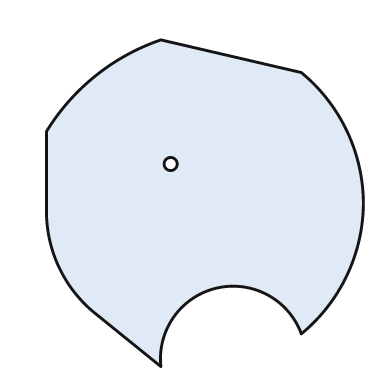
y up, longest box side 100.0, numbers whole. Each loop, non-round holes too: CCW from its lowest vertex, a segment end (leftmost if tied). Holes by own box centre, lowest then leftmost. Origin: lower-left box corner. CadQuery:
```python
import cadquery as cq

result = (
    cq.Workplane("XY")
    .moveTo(35.0, 0.0)
    .threePointArc((52.0, 24.0), (78.0, 10.0))
    .threePointArc((92.0, 28.0), (97.0, 50.0))
    .threePointArc((92.0, 72.0), (78.0, 90.0))
    .lineTo(35.0, 100.0)
    .threePointArc((15.0, 89.0), (0.0, 72.0))
    .lineTo(0.0, 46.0)
    .threePointArc((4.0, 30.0), (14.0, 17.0))
    .close()
    .moveTo(38.0, 62.0)
    .circle(2.0)
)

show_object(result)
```